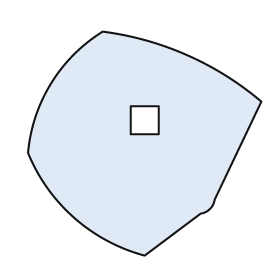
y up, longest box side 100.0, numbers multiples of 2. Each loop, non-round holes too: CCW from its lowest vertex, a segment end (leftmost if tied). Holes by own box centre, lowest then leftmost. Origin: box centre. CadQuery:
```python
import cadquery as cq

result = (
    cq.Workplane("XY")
    .moveTo(0.0, -48.0)
    .lineTo(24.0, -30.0)
    .threePointArc((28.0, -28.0), (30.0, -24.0))
    .lineTo(50.0, 18.0)
    .threePointArc((18.0, 38.0), (-18.0, 48.0))
    .threePointArc((-40.0, 26.0), (-50.0, -4.0))
    .threePointArc((-30.0, -32.0), (0.0, -48.0))
    .close()
    .moveTo(-6.0, 4.0)
    .lineTo(6.0, 4.0)
    .lineTo(6.0, 16.0)
    .lineTo(-6.0, 16.0)
    .close()
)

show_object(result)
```